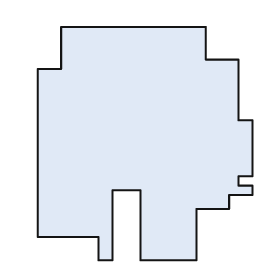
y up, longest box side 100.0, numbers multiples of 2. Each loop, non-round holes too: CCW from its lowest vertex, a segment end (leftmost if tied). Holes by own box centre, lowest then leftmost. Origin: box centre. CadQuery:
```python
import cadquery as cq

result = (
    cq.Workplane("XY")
    .moveTo(-20.0, -50.0)
    .lineTo(-14.0, -50.0)
    .lineTo(-14.0, -20.0)
    .lineTo(-2.0, -20.0)
    .lineTo(-2.0, -50.0)
    .lineTo(22.0, -50.0)
    .lineTo(22.0, -28.0)
    .lineTo(36.0, -28.0)
    .lineTo(36.0, -22.0)
    .lineTo(46.0, -22.0)
    .lineTo(46.0, -18.0)
    .lineTo(40.0, -18.0)
    .lineTo(40.0, -14.0)
    .lineTo(46.0, -14.0)
    .lineTo(46.0, 10.0)
    .lineTo(40.0, 10.0)
    .lineTo(40.0, 36.0)
    .lineTo(26.0, 36.0)
    .lineTo(26.0, 50.0)
    .lineTo(-36.0, 50.0)
    .lineTo(-36.0, 32.0)
    .lineTo(-46.0, 32.0)
    .lineTo(-46.0, -40.0)
    .lineTo(-20.0, -40.0)
    .close()
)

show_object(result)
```